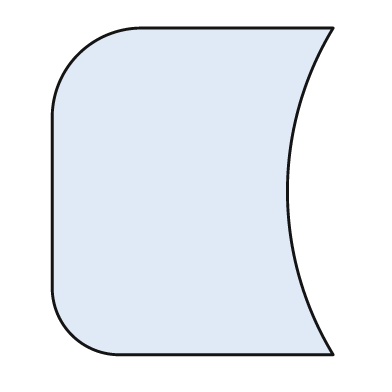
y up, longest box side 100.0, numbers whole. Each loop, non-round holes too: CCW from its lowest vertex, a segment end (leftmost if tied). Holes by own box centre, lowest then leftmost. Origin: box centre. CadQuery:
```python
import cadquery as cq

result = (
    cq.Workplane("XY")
    .moveTo(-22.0, -50.0)
    .lineTo(43.0, -50.0)
    .threePointArc((29.0, 0.0), (43.0, 50.0))
    .lineTo(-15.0, 50.0)
    .threePointArc((-35.0, 42.0), (-43.0, 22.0))
    .lineTo(-43.0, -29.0)
    .threePointArc((-37.0, -44.0), (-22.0, -50.0))
    .close()
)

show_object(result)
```